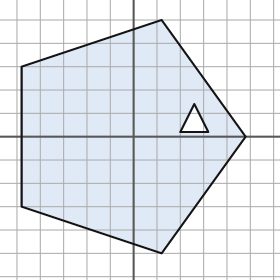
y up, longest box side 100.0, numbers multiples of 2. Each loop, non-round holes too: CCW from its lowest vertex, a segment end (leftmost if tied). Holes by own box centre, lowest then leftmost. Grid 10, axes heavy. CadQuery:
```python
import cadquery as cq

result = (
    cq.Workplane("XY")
    .moveTo(12.0, -50.0)
    .lineTo(48.0, 0.0)
    .lineTo(12.0, 50.0)
    .lineTo(-48.0, 30.0)
    .lineTo(-48.0, -30.0)
    .close()
    .moveTo(20.0, 2.0)
    .lineTo(32.0, 2.0)
    .lineTo(26.0, 14.0)
    .close()
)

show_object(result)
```